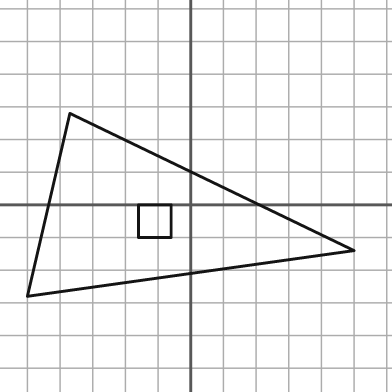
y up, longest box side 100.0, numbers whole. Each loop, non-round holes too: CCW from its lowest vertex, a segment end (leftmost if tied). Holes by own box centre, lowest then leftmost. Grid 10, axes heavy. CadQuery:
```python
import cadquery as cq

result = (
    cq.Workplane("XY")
    .moveTo(-50.0, -28.0)
    .lineTo(50.0, -14.0)
    .lineTo(-37.0, 28.0)
    .close()
    .moveTo(-16.0, -10.0)
    .lineTo(-6.0, -10.0)
    .lineTo(-6.0, 0.0)
    .lineTo(-16.0, 0.0)
    .close()
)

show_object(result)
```